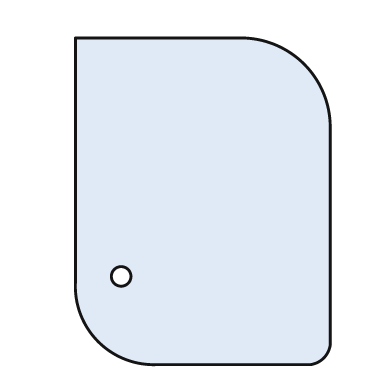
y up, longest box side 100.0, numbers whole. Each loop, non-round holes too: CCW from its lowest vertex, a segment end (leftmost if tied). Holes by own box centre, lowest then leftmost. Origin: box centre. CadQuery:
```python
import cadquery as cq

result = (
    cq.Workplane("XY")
    .moveTo(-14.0, -50.0)
    .lineTo(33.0, -50.0)
    .threePointArc((37.0, -48.0), (39.0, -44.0))
    .lineTo(39.0, 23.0)
    .threePointArc((31.0, 42.0), (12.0, 50.0))
    .lineTo(-39.0, 50.0)
    .lineTo(-39.0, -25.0)
    .threePointArc((-32.0, -43.0), (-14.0, -50.0))
    .close()
    .moveTo(-25.0, -23.0)
    .circle(3.0)
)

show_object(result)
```